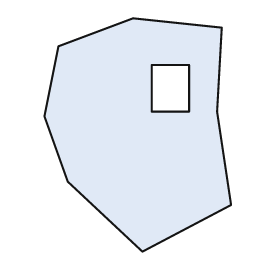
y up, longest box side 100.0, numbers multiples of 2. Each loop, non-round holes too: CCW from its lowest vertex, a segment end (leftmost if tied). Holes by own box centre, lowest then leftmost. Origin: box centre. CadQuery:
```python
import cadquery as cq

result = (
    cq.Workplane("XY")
    .moveTo(2.0, -50.0)
    .lineTo(40.0, -30.0)
    .lineTo(34.0, 10.0)
    .lineTo(36.0, 46.0)
    .lineTo(-2.0, 50.0)
    .lineTo(-34.0, 38.0)
    .lineTo(-40.0, 8.0)
    .lineTo(-30.0, -20.0)
    .close()
    .moveTo(6.0, 10.0)
    .lineTo(22.0, 10.0)
    .lineTo(22.0, 30.0)
    .lineTo(6.0, 30.0)
    .close()
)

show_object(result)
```